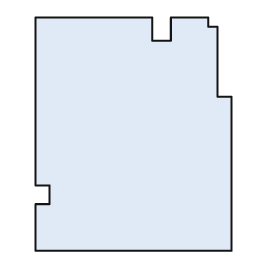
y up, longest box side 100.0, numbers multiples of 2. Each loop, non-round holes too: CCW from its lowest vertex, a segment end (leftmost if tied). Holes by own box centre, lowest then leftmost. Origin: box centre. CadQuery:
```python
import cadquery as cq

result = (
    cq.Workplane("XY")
    .moveTo(-42.0, -50.0)
    .lineTo(42.0, -50.0)
    .lineTo(42.0, 16.0)
    .lineTo(36.0, 16.0)
    .lineTo(36.0, 46.0)
    .lineTo(32.0, 46.0)
    .lineTo(32.0, 50.0)
    .lineTo(16.0, 50.0)
    .lineTo(16.0, 40.0)
    .lineTo(8.0, 40.0)
    .lineTo(8.0, 50.0)
    .lineTo(-42.0, 50.0)
    .lineTo(-42.0, -22.0)
    .lineTo(-36.0, -22.0)
    .lineTo(-36.0, -30.0)
    .lineTo(-42.0, -30.0)
    .close()
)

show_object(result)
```